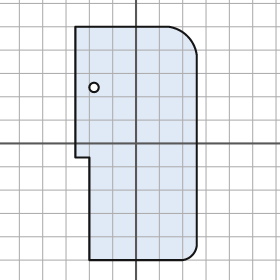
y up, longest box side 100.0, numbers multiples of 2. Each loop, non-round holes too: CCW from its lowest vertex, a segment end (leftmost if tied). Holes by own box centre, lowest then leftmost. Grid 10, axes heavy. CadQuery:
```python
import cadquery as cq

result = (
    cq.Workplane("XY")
    .moveTo(-20.0, -50.0)
    .lineTo(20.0, -50.0)
    .threePointArc((24.0, -48.0), (26.0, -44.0))
    .lineTo(26.0, 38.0)
    .threePointArc((22.0, 46.0), (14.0, 50.0))
    .lineTo(-26.0, 50.0)
    .lineTo(-26.0, -6.0)
    .lineTo(-20.0, -6.0)
    .close()
    .moveTo(-18.0, 24.0)
    .circle(2.0)
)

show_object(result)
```